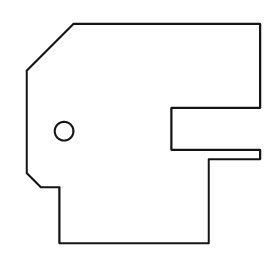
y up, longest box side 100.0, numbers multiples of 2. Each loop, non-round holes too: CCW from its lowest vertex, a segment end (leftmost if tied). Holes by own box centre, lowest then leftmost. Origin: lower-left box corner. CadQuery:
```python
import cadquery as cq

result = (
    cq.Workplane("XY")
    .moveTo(14.0, 0.0)
    .lineTo(78.0, 0.0)
    .lineTo(78.0, 36.0)
    .lineTo(100.0, 36.0)
    .lineTo(100.0, 40.0)
    .lineTo(62.0, 40.0)
    .lineTo(62.0, 58.0)
    .lineTo(100.0, 58.0)
    .lineTo(100.0, 94.0)
    .lineTo(20.0, 94.0)
    .lineTo(0.0, 74.0)
    .lineTo(0.0, 30.0)
    .lineTo(6.0, 24.0)
    .lineTo(14.0, 24.0)
    .close()
    .moveTo(16.0, 48.0)
    .circle(4.0)
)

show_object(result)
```